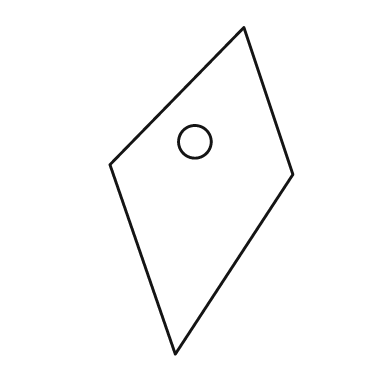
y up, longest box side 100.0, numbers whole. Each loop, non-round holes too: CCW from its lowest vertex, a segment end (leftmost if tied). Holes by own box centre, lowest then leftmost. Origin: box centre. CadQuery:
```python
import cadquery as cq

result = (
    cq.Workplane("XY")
    .moveTo(-8.0, -50.0)
    .lineTo(28.0, 5.0)
    .lineTo(13.0, 50.0)
    .lineTo(-28.0, 8.0)
    .close()
    .moveTo(-2.0, 15.0)
    .circle(5.0)
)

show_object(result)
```